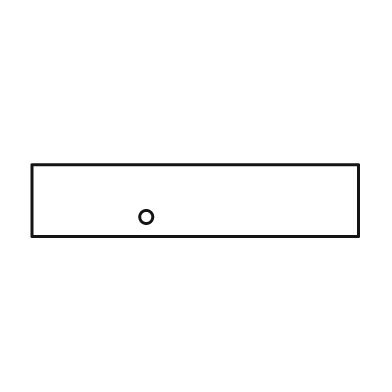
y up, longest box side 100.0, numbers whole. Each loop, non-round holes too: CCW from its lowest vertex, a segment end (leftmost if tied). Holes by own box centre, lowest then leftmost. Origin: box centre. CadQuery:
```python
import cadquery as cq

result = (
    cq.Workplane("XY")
    .moveTo(-50.0, -11.0)
    .lineTo(50.0, -11.0)
    .lineTo(50.0, 11.0)
    .lineTo(-50.0, 11.0)
    .close()
    .moveTo(-15.0, -5.0)
    .circle(2.0)
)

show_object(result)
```